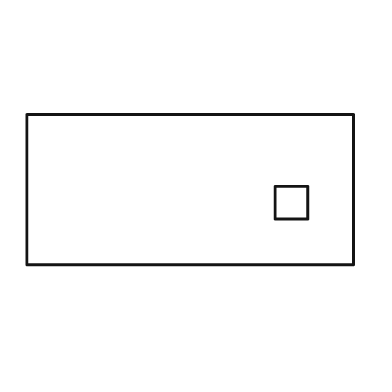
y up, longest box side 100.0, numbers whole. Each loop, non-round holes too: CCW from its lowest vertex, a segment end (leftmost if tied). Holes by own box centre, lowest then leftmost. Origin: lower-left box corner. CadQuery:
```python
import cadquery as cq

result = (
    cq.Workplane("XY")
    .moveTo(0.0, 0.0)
    .lineTo(100.0, 0.0)
    .lineTo(100.0, 46.0)
    .lineTo(0.0, 46.0)
    .close()
    .moveTo(76.0, 14.0)
    .lineTo(86.0, 14.0)
    .lineTo(86.0, 24.0)
    .lineTo(76.0, 24.0)
    .close()
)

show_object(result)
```